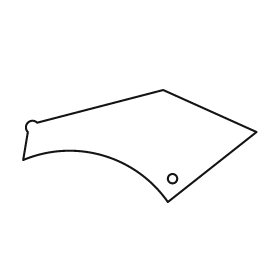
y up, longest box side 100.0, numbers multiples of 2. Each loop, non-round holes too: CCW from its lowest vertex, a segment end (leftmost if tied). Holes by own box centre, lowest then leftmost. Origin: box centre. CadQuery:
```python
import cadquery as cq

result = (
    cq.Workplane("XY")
    .moveTo(12.0, -24.0)
    .lineTo(50.0, 6.0)
    .lineTo(10.0, 24.0)
    .lineTo(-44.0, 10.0)
    .threePointArc((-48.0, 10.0), (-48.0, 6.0))
    .lineTo(-50.0, -6.0)
    .threePointArc((-16.0, -4.0), (12.0, -24.0))
    .close()
    .moveTo(14.0, -14.0)
    .circle(2.0)
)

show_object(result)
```